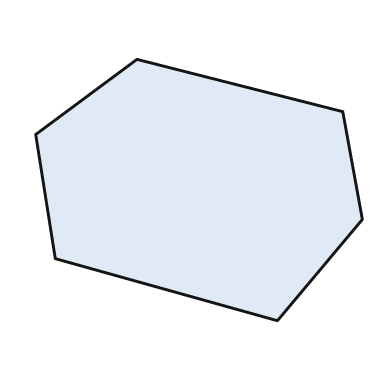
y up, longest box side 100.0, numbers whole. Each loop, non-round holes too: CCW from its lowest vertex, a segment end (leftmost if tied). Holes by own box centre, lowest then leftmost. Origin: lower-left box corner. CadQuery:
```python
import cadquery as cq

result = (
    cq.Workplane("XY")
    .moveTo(74.0, 0.0)
    .lineTo(100.0, 31.0)
    .lineTo(94.0, 64.0)
    .lineTo(31.0, 80.0)
    .lineTo(0.0, 57.0)
    .lineTo(6.0, 19.0)
    .close()
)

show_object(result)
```